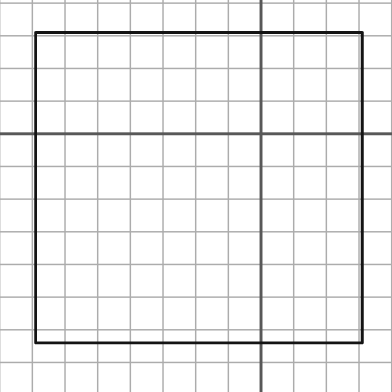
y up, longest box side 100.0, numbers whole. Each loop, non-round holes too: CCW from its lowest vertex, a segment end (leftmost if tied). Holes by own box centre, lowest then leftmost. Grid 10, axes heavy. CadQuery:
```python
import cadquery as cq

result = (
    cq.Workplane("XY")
    .moveTo(-69.0, -64.0)
    .lineTo(31.0, -64.0)
    .lineTo(31.0, 31.0)
    .lineTo(-69.0, 31.0)
    .close()
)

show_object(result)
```